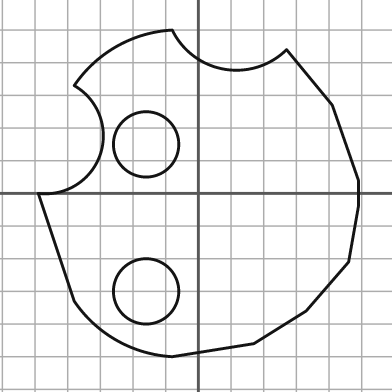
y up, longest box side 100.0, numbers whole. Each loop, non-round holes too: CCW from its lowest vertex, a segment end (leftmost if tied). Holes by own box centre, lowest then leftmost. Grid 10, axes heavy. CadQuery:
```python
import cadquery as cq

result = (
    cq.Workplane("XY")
    .moveTo(-8.0, -50.0)
    .lineTo(17.0, -46.0)
    .lineTo(33.0, -36.0)
    .lineTo(46.0, -21.0)
    .lineTo(49.0, -4.0)
    .lineTo(49.0, 4.0)
    .lineTo(41.0, 27.0)
    .lineTo(27.0, 44.0)
    .threePointArc((8.0, 38.0), (-8.0, 50.0))
    .threePointArc((-25.0, 45.0), (-38.0, 33.0))
    .threePointArc((-30.0, 12.0), (-49.0, 0.0))
    .lineTo(-38.0, -33.0)
    .threePointArc((-25.0, -45.0), (-8.0, -50.0))
    .close()
    .moveTo(-16.0, -30.0)
    .circle(10.0)
    .moveTo(-16.0, 15.0)
    .circle(10.0)
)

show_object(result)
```